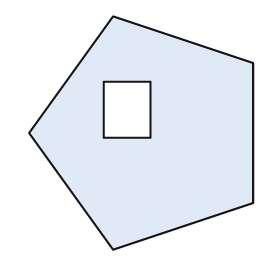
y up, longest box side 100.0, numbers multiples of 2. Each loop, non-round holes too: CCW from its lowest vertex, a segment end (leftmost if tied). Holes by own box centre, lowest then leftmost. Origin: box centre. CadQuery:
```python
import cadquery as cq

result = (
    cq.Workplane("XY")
    .moveTo(-12.0, -50.0)
    .lineTo(48.0, -30.0)
    .lineTo(48.0, 30.0)
    .lineTo(-12.0, 50.0)
    .lineTo(-48.0, 0.0)
    .close()
    .moveTo(-16.0, -2.0)
    .lineTo(4.0, -2.0)
    .lineTo(4.0, 22.0)
    .lineTo(-16.0, 22.0)
    .close()
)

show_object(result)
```